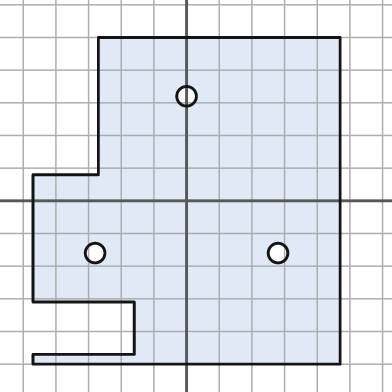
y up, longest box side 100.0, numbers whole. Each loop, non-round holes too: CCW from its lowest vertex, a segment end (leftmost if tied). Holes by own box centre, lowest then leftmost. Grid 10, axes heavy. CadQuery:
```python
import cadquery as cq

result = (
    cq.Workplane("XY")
    .moveTo(-47.0, -50.0)
    .lineTo(47.0, -50.0)
    .lineTo(47.0, 50.0)
    .lineTo(-27.0, 50.0)
    .lineTo(-27.0, 8.0)
    .lineTo(-47.0, 8.0)
    .lineTo(-47.0, -31.0)
    .lineTo(-16.0, -31.0)
    .lineTo(-16.0, -47.0)
    .lineTo(-47.0, -47.0)
    .close()
    .moveTo(-28.0, -16.0)
    .circle(3.0)
    .moveTo(28.0, -16.0)
    .circle(3.0)
    .moveTo(0.0, 32.0)
    .circle(3.0)
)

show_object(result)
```